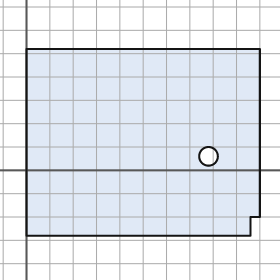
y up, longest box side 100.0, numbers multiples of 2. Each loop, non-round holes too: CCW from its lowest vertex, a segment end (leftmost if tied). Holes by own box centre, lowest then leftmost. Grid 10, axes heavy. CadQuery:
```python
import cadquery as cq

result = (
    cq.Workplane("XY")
    .moveTo(0.0, -28.0)
    .lineTo(96.0, -28.0)
    .lineTo(96.0, -20.0)
    .lineTo(100.0, -20.0)
    .lineTo(100.0, 52.0)
    .lineTo(0.0, 52.0)
    .close()
    .moveTo(78.0, 6.0)
    .circle(4.0)
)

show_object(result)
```